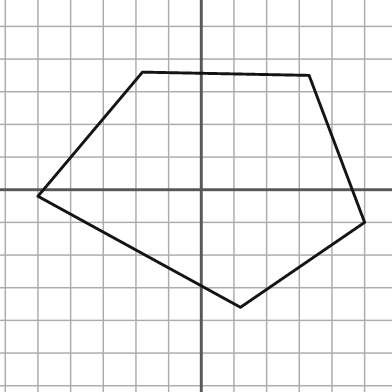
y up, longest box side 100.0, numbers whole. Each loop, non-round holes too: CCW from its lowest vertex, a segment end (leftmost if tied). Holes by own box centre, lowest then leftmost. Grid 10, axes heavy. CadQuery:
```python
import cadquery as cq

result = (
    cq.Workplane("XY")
    .moveTo(12.0, -36.0)
    .lineTo(50.0, -10.0)
    .lineTo(33.0, 35.0)
    .lineTo(-18.0, 36.0)
    .lineTo(-50.0, -2.0)
    .close()
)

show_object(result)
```